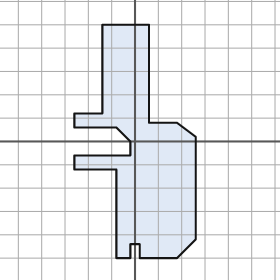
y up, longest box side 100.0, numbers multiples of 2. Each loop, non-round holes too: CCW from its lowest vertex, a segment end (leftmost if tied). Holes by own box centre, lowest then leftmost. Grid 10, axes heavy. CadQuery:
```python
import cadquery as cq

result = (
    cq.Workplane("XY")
    .moveTo(-8.0, -50.0)
    .lineTo(-2.0, -50.0)
    .lineTo(-2.0, -44.0)
    .lineTo(2.0, -44.0)
    .lineTo(2.0, -50.0)
    .lineTo(18.0, -50.0)
    .lineTo(26.0, -42.0)
    .lineTo(26.0, 2.0)
    .lineTo(18.0, 8.0)
    .lineTo(6.0, 8.0)
    .lineTo(6.0, 50.0)
    .lineTo(-14.0, 50.0)
    .lineTo(-14.0, 12.0)
    .lineTo(-26.0, 12.0)
    .lineTo(-26.0, 6.0)
    .lineTo(-8.0, 6.0)
    .lineTo(-2.0, 0.0)
    .lineTo(-2.0, -6.0)
    .lineTo(-26.0, -6.0)
    .lineTo(-26.0, -12.0)
    .lineTo(-8.0, -12.0)
    .close()
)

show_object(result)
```